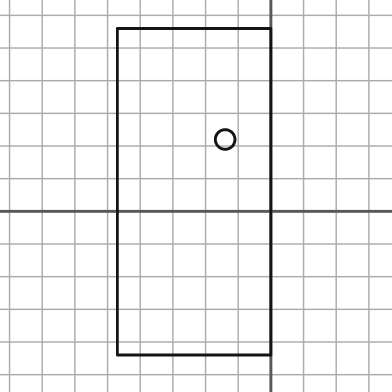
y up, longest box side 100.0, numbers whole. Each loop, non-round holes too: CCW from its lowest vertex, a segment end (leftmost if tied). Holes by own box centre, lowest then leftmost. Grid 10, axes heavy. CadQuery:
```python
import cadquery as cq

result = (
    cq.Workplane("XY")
    .moveTo(-47.0, -44.0)
    .lineTo(0.0, -44.0)
    .lineTo(0.0, 56.0)
    .lineTo(-47.0, 56.0)
    .close()
    .moveTo(-14.0, 22.0)
    .circle(3.0)
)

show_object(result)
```